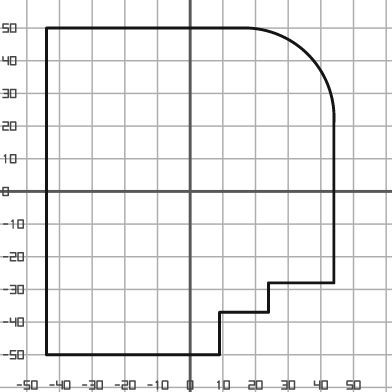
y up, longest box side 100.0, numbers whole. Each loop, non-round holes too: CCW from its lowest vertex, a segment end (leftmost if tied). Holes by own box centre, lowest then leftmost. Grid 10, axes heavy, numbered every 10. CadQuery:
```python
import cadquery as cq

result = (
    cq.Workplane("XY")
    .moveTo(-44.0, -50.0)
    .lineTo(9.0, -50.0)
    .lineTo(9.0, -37.0)
    .lineTo(24.0, -37.0)
    .lineTo(24.0, -28.0)
    .lineTo(44.0, -28.0)
    .lineTo(44.0, 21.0)
    .threePointArc((36.0, 42.0), (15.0, 50.0))
    .lineTo(-44.0, 50.0)
    .close()
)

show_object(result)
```